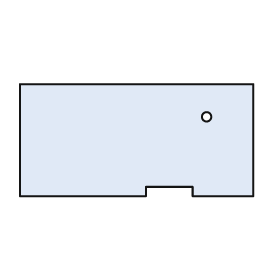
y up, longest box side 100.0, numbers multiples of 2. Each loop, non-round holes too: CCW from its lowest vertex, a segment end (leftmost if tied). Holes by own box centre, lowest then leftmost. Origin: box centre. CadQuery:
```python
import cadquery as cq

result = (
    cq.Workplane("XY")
    .moveTo(-50.0, -24.0)
    .lineTo(4.0, -24.0)
    .lineTo(4.0, -20.0)
    .lineTo(24.0, -20.0)
    .lineTo(24.0, -24.0)
    .lineTo(50.0, -24.0)
    .lineTo(50.0, 24.0)
    .lineTo(-50.0, 24.0)
    .close()
    .moveTo(30.0, 10.0)
    .circle(2.0)
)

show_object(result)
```